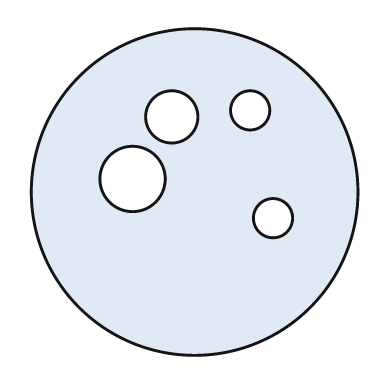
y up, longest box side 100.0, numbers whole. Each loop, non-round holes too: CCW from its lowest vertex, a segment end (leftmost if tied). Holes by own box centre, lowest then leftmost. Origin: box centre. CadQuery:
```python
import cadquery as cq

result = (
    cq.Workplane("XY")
    .moveTo(0.0, 0.0)
    .circle(50.0)
    .moveTo(24.0, -8.0)
    .circle(6.0)
    .moveTo(-19.0, 4.0)
    .circle(10.0)
    .moveTo(-7.0, 23.0)
    .circle(8.0)
    .moveTo(17.0, 25.0)
    .circle(6.0)
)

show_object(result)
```